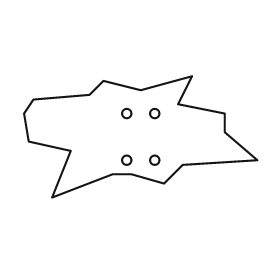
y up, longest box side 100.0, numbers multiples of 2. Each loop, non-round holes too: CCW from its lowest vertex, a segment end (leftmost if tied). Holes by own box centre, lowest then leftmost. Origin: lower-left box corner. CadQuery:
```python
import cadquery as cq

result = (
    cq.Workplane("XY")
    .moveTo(12.0, 0.0)
    .lineTo(38.0, 10.0)
    .lineTo(46.0, 10.0)
    .lineTo(60.0, 6.0)
    .lineTo(68.0, 14.0)
    .lineTo(100.0, 16.0)
    .lineTo(86.0, 28.0)
    .lineTo(86.0, 36.0)
    .lineTo(66.0, 40.0)
    .lineTo(72.0, 52.0)
    .lineTo(50.0, 46.0)
    .lineTo(34.0, 50.0)
    .lineTo(28.0, 44.0)
    .lineTo(4.0, 42.0)
    .lineTo(0.0, 36.0)
    .lineTo(2.0, 24.0)
    .lineTo(20.0, 20.0)
    .close()
    .moveTo(44.0, 16.0)
    .circle(2.0)
    .moveTo(56.0, 16.0)
    .circle(2.0)
    .moveTo(44.0, 36.0)
    .circle(2.0)
    .moveTo(56.0, 36.0)
    .circle(2.0)
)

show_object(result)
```